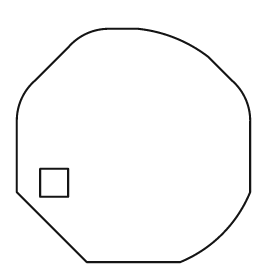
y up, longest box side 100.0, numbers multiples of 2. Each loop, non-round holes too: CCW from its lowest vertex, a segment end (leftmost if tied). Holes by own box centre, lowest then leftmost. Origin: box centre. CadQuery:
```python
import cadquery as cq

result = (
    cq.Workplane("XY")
    .moveTo(-20.0, -50.0)
    .lineTo(20.0, -50.0)
    .threePointArc((38.0, -38.0), (50.0, -20.0))
    .lineTo(50.0, 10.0)
    .threePointArc((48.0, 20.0), (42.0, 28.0))
    .lineTo(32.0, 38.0)
    .threePointArc((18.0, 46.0), (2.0, 50.0))
    .lineTo(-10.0, 50.0)
    .threePointArc((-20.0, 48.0), (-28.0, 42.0))
    .lineTo(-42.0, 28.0)
    .threePointArc((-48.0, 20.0), (-50.0, 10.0))
    .lineTo(-50.0, -20.0)
    .close()
    .moveTo(-40.0, -22.0)
    .lineTo(-28.0, -22.0)
    .lineTo(-28.0, -10.0)
    .lineTo(-40.0, -10.0)
    .close()
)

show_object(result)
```